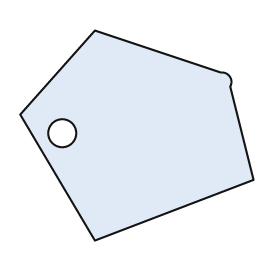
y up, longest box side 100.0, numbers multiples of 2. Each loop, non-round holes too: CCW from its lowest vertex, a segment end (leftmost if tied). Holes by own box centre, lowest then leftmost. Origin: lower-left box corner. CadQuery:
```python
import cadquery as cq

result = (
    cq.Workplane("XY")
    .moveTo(32.0, 0.0)
    .lineTo(100.0, 26.0)
    .lineTo(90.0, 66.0)
    .threePointArc((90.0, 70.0), (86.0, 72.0))
    .lineTo(32.0, 90.0)
    .lineTo(0.0, 54.0)
    .close()
    .moveTo(18.0, 46.0)
    .circle(6.0)
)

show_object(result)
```